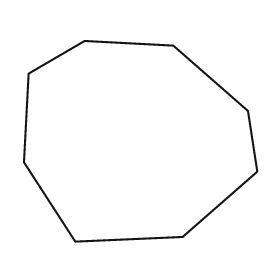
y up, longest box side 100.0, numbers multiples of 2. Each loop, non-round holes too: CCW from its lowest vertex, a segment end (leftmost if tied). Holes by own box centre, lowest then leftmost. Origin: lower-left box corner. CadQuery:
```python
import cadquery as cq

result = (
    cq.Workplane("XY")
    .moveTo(22.0, 0.0)
    .lineTo(68.0, 2.0)
    .lineTo(100.0, 30.0)
    .lineTo(96.0, 56.0)
    .lineTo(64.0, 84.0)
    .lineTo(26.0, 86.0)
    .lineTo(2.0, 72.0)
    .lineTo(0.0, 34.0)
    .close()
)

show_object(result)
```